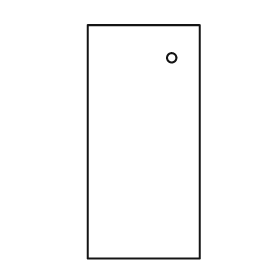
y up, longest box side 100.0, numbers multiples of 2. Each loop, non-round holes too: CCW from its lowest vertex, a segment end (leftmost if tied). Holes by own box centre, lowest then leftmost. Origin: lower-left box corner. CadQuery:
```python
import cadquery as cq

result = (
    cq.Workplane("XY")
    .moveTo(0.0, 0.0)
    .lineTo(48.0, 0.0)
    .lineTo(48.0, 100.0)
    .lineTo(0.0, 100.0)
    .close()
    .moveTo(36.0, 86.0)
    .circle(2.0)
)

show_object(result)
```